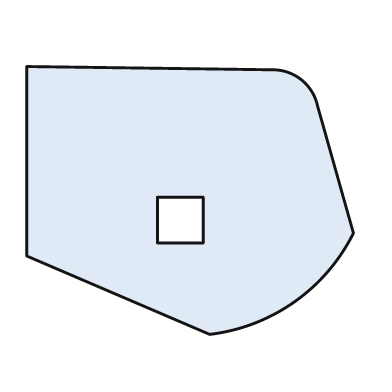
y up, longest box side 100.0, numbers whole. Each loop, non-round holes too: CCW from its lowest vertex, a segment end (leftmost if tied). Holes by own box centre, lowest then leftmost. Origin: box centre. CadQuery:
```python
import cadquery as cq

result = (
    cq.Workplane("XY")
    .moveTo(6.0, -41.0)
    .threePointArc((32.0, -31.0), (50.0, -10.0))
    .lineTo(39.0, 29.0)
    .threePointArc((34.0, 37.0), (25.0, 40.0))
    .lineTo(-50.0, 41.0)
    .lineTo(-50.0, -17.0)
    .close()
    .moveTo(-10.0, -13.0)
    .lineTo(4.0, -13.0)
    .lineTo(4.0, 1.0)
    .lineTo(-10.0, 1.0)
    .close()
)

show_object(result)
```